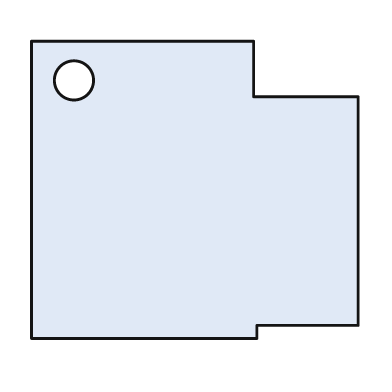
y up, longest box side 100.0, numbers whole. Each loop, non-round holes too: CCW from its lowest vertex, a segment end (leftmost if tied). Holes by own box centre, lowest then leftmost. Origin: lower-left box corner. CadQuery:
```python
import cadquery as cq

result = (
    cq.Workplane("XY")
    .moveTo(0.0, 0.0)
    .lineTo(69.0, 0.0)
    .lineTo(69.0, 4.0)
    .lineTo(100.0, 4.0)
    .lineTo(100.0, 74.0)
    .lineTo(68.0, 74.0)
    .lineTo(68.0, 91.0)
    .lineTo(0.0, 91.0)
    .close()
    .moveTo(13.0, 79.0)
    .circle(6.0)
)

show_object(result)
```